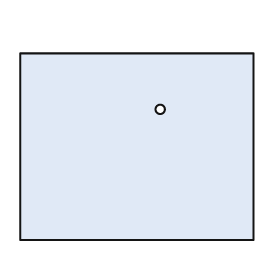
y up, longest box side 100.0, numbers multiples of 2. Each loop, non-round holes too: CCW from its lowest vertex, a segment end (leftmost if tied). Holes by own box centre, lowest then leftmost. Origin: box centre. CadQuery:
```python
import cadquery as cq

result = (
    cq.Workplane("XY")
    .moveTo(-50.0, -40.0)
    .lineTo(50.0, -40.0)
    .lineTo(50.0, 40.0)
    .lineTo(-50.0, 40.0)
    .close()
    .moveTo(10.0, 16.0)
    .circle(2.0)
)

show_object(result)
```